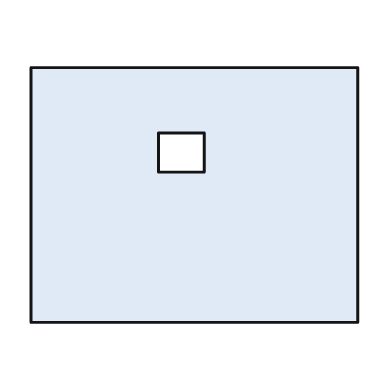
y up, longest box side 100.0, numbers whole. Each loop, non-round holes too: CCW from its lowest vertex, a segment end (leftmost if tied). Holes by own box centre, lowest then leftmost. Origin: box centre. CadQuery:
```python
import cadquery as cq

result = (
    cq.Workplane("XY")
    .moveTo(-50.0, -39.0)
    .lineTo(50.0, -39.0)
    .lineTo(50.0, 39.0)
    .lineTo(-50.0, 39.0)
    .close()
    .moveTo(-11.0, 7.0)
    .lineTo(3.0, 7.0)
    .lineTo(3.0, 19.0)
    .lineTo(-11.0, 19.0)
    .close()
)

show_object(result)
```